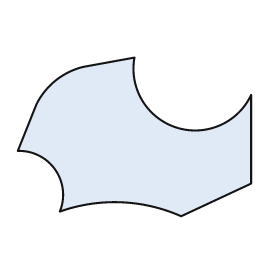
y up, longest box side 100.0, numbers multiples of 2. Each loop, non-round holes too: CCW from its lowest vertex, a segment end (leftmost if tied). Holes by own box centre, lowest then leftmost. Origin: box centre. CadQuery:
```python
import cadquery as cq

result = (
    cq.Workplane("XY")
    .moveTo(20.0, -34.0)
    .lineTo(50.0, -20.0)
    .lineTo(50.0, 18.0)
    .threePointArc((18.0, 4.0), (0.0, 34.0))
    .lineTo(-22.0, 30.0)
    .threePointArc((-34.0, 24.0), (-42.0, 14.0))
    .lineTo(-50.0, -6.0)
    .threePointArc((-34.0, -14.0), (-32.0, -32.0))
    .threePointArc((-6.0, -28.0), (20.0, -34.0))
    .close()
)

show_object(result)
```